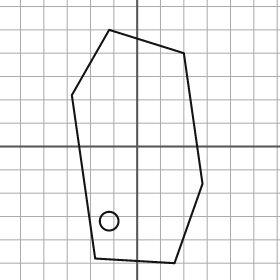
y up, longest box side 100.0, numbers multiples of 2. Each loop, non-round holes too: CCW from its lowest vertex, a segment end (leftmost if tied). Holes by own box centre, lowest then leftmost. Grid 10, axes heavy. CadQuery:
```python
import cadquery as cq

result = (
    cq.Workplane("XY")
    .moveTo(16.0, -50.0)
    .lineTo(28.0, -16.0)
    .lineTo(20.0, 40.0)
    .lineTo(-12.0, 50.0)
    .lineTo(-28.0, 22.0)
    .lineTo(-18.0, -48.0)
    .close()
    .moveTo(-12.0, -32.0)
    .circle(4.0)
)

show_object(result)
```